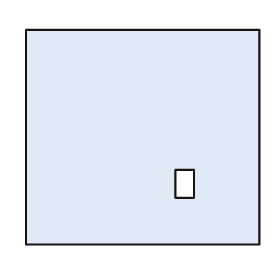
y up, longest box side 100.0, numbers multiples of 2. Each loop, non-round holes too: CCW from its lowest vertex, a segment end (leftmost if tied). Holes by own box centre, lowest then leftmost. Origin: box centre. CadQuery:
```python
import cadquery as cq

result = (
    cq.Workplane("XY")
    .moveTo(-50.0, -46.0)
    .lineTo(50.0, -46.0)
    .lineTo(50.0, 46.0)
    .lineTo(-50.0, 46.0)
    .close()
    .moveTo(14.0, -26.0)
    .lineTo(22.0, -26.0)
    .lineTo(22.0, -14.0)
    .lineTo(14.0, -14.0)
    .close()
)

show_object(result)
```